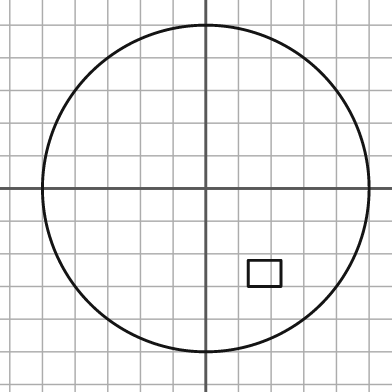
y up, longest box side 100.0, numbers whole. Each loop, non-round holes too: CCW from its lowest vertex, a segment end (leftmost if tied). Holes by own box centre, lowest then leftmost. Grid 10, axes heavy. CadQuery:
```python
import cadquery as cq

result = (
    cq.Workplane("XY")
    .moveTo(0.0, 0.0)
    .circle(50.0)
    .moveTo(13.0, -30.0)
    .lineTo(23.0, -30.0)
    .lineTo(23.0, -22.0)
    .lineTo(13.0, -22.0)
    .close()
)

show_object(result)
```